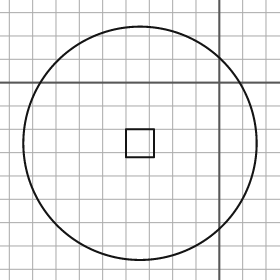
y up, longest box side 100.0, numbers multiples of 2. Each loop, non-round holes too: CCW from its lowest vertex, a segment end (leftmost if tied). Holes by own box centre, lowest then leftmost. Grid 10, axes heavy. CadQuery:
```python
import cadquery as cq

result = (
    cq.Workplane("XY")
    .moveTo(-34.0, -26.0)
    .circle(50.0)
    .moveTo(-40.0, -32.0)
    .lineTo(-28.0, -32.0)
    .lineTo(-28.0, -20.0)
    .lineTo(-40.0, -20.0)
    .close()
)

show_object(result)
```